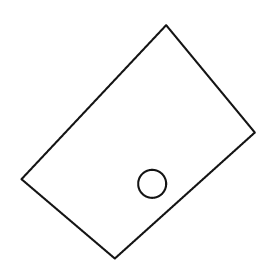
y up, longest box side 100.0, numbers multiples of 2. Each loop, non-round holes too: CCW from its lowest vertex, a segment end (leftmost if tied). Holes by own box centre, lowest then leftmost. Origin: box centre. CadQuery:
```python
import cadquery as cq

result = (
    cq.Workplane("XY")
    .moveTo(-10.0, -50.0)
    .lineTo(50.0, 4.0)
    .lineTo(12.0, 50.0)
    .lineTo(-50.0, -16.0)
    .close()
    .moveTo(6.0, -18.0)
    .circle(6.0)
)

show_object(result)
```